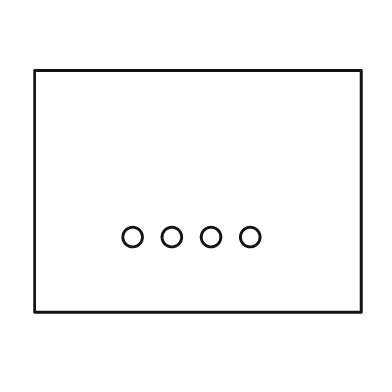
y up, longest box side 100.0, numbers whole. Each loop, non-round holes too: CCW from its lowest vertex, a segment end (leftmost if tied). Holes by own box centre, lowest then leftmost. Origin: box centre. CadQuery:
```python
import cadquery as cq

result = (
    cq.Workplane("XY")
    .moveTo(-50.0, -37.0)
    .lineTo(50.0, -37.0)
    .lineTo(50.0, 37.0)
    .lineTo(-50.0, 37.0)
    .close()
    .moveTo(-20.0, -14.0)
    .circle(3.0)
    .moveTo(-8.0, -14.0)
    .circle(3.0)
    .moveTo(4.0, -14.0)
    .circle(3.0)
    .moveTo(16.0, -14.0)
    .circle(3.0)
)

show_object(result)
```